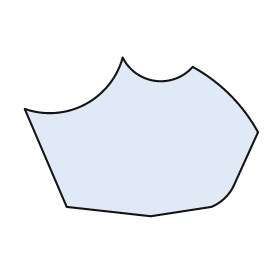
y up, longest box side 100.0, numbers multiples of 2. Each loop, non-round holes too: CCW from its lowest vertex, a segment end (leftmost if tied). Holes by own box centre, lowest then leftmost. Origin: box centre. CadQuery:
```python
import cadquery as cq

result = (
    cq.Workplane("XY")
    .moveTo(4.0, -34.0)
    .lineTo(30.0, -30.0)
    .threePointArc((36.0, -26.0), (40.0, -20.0))
    .lineTo(50.0, 2.0)
    .threePointArc((38.0, 18.0), (22.0, 30.0))
    .threePointArc((6.0, 24.0), (-8.0, 34.0))
    .threePointArc((-24.0, 14.0), (-50.0, 12.0))
    .lineTo(-32.0, -30.0)
    .close()
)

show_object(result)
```